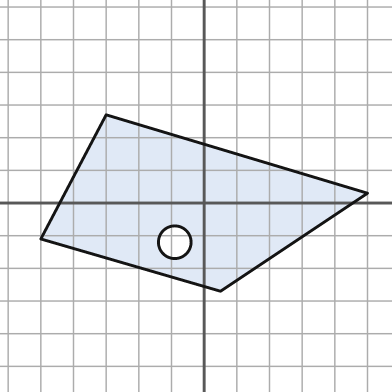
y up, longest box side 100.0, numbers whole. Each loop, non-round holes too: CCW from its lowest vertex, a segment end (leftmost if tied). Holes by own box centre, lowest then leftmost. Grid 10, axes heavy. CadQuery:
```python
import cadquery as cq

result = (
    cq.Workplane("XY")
    .moveTo(5.0, -27.0)
    .lineTo(50.0, 3.0)
    .lineTo(-30.0, 27.0)
    .lineTo(-50.0, -11.0)
    .close()
    .moveTo(-9.0, -12.0)
    .circle(5.0)
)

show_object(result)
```